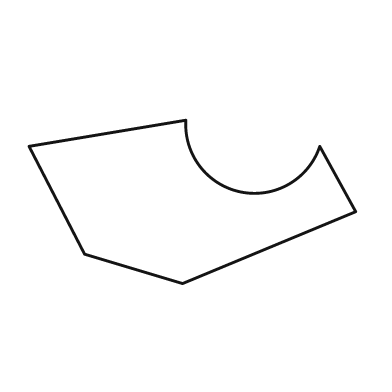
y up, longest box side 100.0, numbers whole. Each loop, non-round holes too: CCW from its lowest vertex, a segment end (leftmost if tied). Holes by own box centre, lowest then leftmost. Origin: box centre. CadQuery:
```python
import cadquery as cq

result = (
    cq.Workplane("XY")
    .moveTo(-3.0, -25.0)
    .lineTo(50.0, -3.0)
    .lineTo(39.0, 17.0)
    .threePointArc((15.0, 3.0), (-2.0, 25.0))
    .lineTo(-50.0, 17.0)
    .lineTo(-33.0, -16.0)
    .close()
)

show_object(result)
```